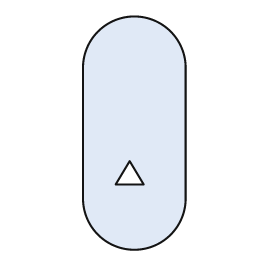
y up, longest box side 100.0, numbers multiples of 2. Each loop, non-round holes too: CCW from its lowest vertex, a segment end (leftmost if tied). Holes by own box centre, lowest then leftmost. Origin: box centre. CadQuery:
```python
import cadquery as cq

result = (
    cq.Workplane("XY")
    .moveTo(-22.0, -28.0)
    .threePointArc((0.0, -50.0), (22.0, -28.0))
    .lineTo(22.0, 28.0)
    .threePointArc((0.0, 50.0), (-22.0, 28.0))
    .close()
    .moveTo(-8.0, -22.0)
    .lineTo(4.0, -22.0)
    .lineTo(-2.0, -12.0)
    .close()
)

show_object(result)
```